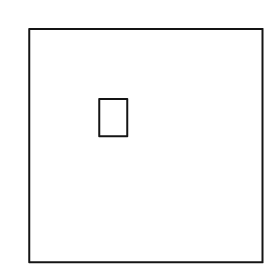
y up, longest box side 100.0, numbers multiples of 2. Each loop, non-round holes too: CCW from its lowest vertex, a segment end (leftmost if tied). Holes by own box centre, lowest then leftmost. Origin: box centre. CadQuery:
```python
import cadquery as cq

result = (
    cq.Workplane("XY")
    .moveTo(-50.0, -50.0)
    .lineTo(50.0, -50.0)
    .lineTo(50.0, 50.0)
    .lineTo(-50.0, 50.0)
    .close()
    .moveTo(-20.0, 4.0)
    .lineTo(-8.0, 4.0)
    .lineTo(-8.0, 20.0)
    .lineTo(-20.0, 20.0)
    .close()
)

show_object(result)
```